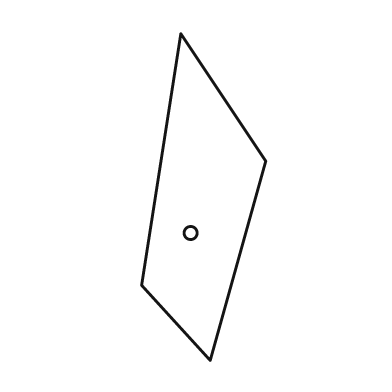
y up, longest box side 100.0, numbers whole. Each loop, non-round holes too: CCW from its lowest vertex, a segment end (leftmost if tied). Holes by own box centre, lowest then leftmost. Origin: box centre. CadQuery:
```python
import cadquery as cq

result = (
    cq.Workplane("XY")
    .moveTo(2.0, -50.0)
    .lineTo(19.0, 11.0)
    .lineTo(-7.0, 50.0)
    .lineTo(-19.0, -27.0)
    .close()
    .moveTo(-4.0, -11.0)
    .circle(2.0)
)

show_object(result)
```